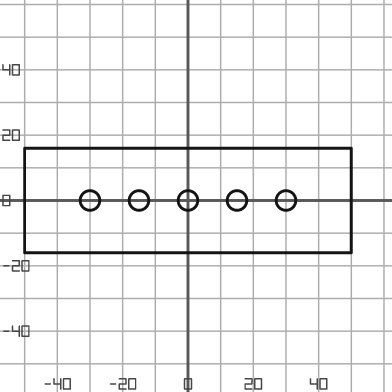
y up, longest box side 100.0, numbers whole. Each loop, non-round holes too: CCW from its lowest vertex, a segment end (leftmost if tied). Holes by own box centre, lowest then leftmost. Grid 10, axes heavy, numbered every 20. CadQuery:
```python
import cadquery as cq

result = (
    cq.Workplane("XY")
    .moveTo(-50.0, -16.0)
    .lineTo(50.0, -16.0)
    .lineTo(50.0, 16.0)
    .lineTo(-50.0, 16.0)
    .close()
    .moveTo(-30.0, 0.0)
    .circle(3.0)
    .moveTo(-15.0, 0.0)
    .circle(3.0)
    .moveTo(0.0, 0.0)
    .circle(3.0)
    .moveTo(15.0, 0.0)
    .circle(3.0)
    .moveTo(30.0, 0.0)
    .circle(3.0)
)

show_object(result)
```